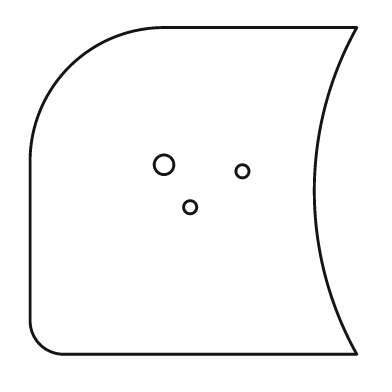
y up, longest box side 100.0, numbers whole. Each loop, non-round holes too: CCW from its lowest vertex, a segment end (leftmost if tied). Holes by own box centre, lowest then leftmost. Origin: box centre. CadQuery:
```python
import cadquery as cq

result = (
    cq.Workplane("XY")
    .moveTo(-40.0, -50.0)
    .lineTo(50.0, -50.0)
    .threePointArc((37.0, 0.0), (50.0, 50.0))
    .lineTo(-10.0, 50.0)
    .threePointArc((-38.0, 38.0), (-50.0, 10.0))
    .lineTo(-50.0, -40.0)
    .threePointArc((-47.0, -47.0), (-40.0, -50.0))
    .close()
    .moveTo(-1.0, -5.0)
    .circle(2.0)
    .moveTo(15.0, 6.0)
    .circle(2.0)
    .moveTo(-9.0, 8.0)
    .circle(3.0)
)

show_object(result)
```